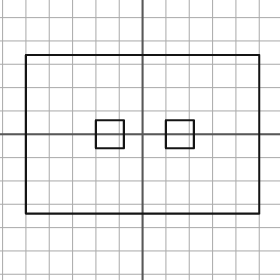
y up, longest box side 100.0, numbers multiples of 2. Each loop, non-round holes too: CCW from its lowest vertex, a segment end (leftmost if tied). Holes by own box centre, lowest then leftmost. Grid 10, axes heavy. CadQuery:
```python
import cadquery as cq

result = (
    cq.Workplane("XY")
    .moveTo(-50.0, -34.0)
    .lineTo(50.0, -34.0)
    .lineTo(50.0, 34.0)
    .lineTo(-50.0, 34.0)
    .close()
    .moveTo(-20.0, -6.0)
    .lineTo(-8.0, -6.0)
    .lineTo(-8.0, 6.0)
    .lineTo(-20.0, 6.0)
    .close()
    .moveTo(10.0, -6.0)
    .lineTo(22.0, -6.0)
    .lineTo(22.0, 6.0)
    .lineTo(10.0, 6.0)
    .close()
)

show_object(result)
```